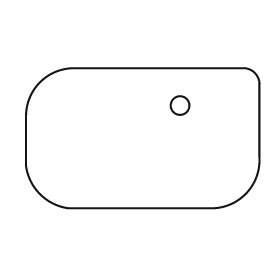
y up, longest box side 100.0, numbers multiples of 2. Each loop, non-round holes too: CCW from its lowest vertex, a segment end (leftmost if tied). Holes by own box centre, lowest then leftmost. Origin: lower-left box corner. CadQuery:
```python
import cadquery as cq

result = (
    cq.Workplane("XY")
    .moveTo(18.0, 0.0)
    .lineTo(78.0, 0.0)
    .threePointArc((94.0, 6.0), (100.0, 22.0))
    .lineTo(100.0, 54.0)
    .threePointArc((98.0, 58.0), (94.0, 60.0))
    .lineTo(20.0, 60.0)
    .threePointArc((6.0, 54.0), (0.0, 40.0))
    .lineTo(0.0, 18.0)
    .threePointArc((6.0, 6.0), (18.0, 0.0))
    .close()
    .moveTo(66.0, 44.0)
    .circle(4.0)
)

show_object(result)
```